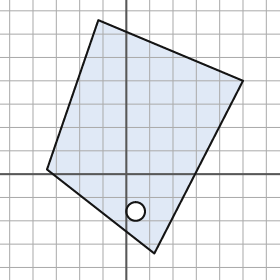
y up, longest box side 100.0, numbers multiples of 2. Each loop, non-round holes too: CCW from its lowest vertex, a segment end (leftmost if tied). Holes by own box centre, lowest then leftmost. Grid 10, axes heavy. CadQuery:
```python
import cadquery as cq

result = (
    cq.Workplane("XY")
    .moveTo(12.0, -34.0)
    .lineTo(50.0, 40.0)
    .lineTo(-12.0, 66.0)
    .lineTo(-34.0, 2.0)
    .close()
    .moveTo(4.0, -16.0)
    .circle(4.0)
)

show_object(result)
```